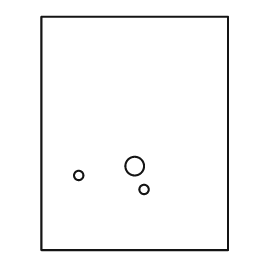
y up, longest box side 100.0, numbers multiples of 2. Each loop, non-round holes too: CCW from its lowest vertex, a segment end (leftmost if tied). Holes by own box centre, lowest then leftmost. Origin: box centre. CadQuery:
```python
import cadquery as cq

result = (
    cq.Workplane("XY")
    .moveTo(-40.0, -50.0)
    .lineTo(40.0, -50.0)
    .lineTo(40.0, 50.0)
    .lineTo(-40.0, 50.0)
    .close()
    .moveTo(4.0, -24.0)
    .circle(2.0)
    .moveTo(-24.0, -18.0)
    .circle(2.0)
    .moveTo(0.0, -14.0)
    .circle(4.0)
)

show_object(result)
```